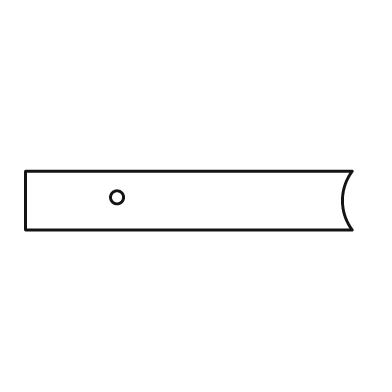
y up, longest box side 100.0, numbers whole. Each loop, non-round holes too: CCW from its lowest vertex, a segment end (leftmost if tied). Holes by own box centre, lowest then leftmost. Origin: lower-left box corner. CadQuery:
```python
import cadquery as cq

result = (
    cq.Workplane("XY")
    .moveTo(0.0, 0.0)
    .lineTo(100.0, 0.0)
    .threePointArc((97.0, 9.0), (100.0, 18.0))
    .lineTo(0.0, 18.0)
    .close()
    .moveTo(28.0, 10.0)
    .circle(2.0)
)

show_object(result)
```